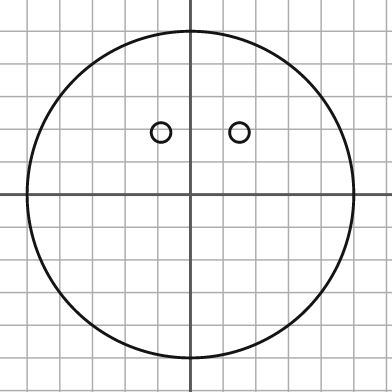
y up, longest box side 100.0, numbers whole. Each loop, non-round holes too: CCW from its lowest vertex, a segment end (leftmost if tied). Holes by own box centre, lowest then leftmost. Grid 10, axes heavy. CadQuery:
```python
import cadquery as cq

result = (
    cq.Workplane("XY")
    .moveTo(0.0, 0.0)
    .circle(50.0)
    .moveTo(-9.0, 19.0)
    .circle(3.0)
    .moveTo(15.0, 19.0)
    .circle(3.0)
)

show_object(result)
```